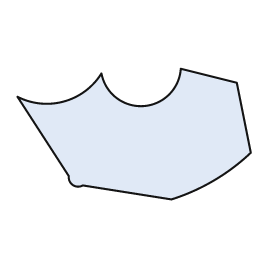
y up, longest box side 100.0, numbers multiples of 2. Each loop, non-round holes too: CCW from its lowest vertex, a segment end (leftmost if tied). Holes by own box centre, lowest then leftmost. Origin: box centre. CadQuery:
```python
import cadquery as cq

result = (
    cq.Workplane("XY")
    .moveTo(16.0, -28.0)
    .threePointArc((34.0, -20.0), (50.0, -8.0))
    .lineTo(44.0, 22.0)
    .lineTo(20.0, 28.0)
    .threePointArc((4.0, 12.0), (-14.0, 26.0))
    .threePointArc((-30.0, 14.0), (-50.0, 16.0))
    .lineTo(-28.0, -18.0)
    .threePointArc((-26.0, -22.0), (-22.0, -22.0))
    .close()
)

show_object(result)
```